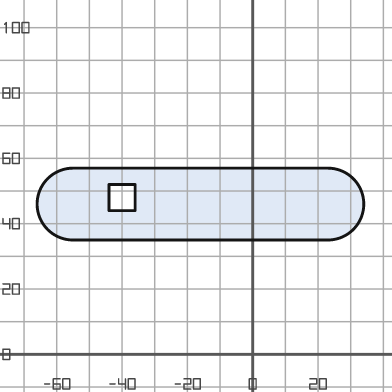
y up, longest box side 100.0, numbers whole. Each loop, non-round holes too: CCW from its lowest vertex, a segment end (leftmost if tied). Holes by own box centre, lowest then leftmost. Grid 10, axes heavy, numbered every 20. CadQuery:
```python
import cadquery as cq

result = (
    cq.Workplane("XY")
    .moveTo(-55.0, 35.0)
    .lineTo(23.0, 35.0)
    .threePointArc((34.0, 46.0), (23.0, 57.0))
    .lineTo(-55.0, 57.0)
    .threePointArc((-66.0, 46.0), (-55.0, 35.0))
    .close()
    .moveTo(-44.0, 44.0)
    .lineTo(-36.0, 44.0)
    .lineTo(-36.0, 52.0)
    .lineTo(-44.0, 52.0)
    .close()
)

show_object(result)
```